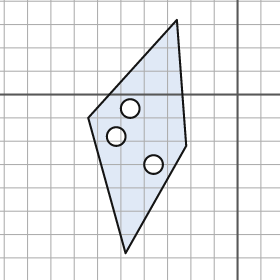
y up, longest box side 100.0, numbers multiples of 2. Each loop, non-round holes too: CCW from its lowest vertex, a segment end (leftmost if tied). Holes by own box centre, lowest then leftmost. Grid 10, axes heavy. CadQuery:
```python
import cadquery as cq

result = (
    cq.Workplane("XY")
    .moveTo(-48.0, -68.0)
    .lineTo(-22.0, -22.0)
    .lineTo(-26.0, 32.0)
    .lineTo(-64.0, -10.0)
    .close()
    .moveTo(-36.0, -30.0)
    .circle(4.0)
    .moveTo(-52.0, -18.0)
    .circle(4.0)
    .moveTo(-46.0, -6.0)
    .circle(4.0)
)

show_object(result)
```